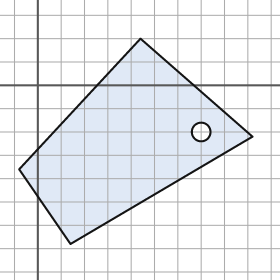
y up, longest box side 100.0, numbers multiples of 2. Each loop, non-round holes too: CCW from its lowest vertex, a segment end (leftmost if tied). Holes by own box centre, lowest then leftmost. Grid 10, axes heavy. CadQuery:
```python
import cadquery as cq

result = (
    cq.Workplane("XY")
    .moveTo(14.0, -68.0)
    .lineTo(92.0, -22.0)
    .lineTo(44.0, 20.0)
    .lineTo(-8.0, -36.0)
    .close()
    .moveTo(70.0, -20.0)
    .circle(4.0)
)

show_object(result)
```